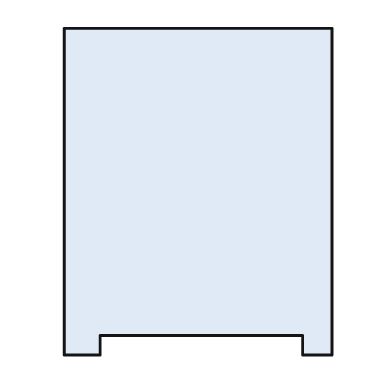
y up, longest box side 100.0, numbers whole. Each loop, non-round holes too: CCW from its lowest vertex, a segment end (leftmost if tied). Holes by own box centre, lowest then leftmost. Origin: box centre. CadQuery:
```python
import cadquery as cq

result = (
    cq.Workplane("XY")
    .moveTo(-41.0, -50.0)
    .lineTo(-30.0, -50.0)
    .lineTo(-30.0, -44.0)
    .lineTo(32.0, -44.0)
    .lineTo(32.0, -50.0)
    .lineTo(41.0, -50.0)
    .lineTo(41.0, 50.0)
    .lineTo(-41.0, 50.0)
    .close()
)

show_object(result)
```